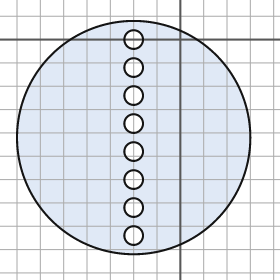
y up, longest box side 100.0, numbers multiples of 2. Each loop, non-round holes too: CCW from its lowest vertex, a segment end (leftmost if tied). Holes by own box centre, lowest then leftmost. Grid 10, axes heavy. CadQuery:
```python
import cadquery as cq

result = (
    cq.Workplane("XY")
    .moveTo(-20.0, -42.0)
    .circle(50.0)
    .moveTo(-20.0, -84.0)
    .circle(4.0)
    .moveTo(-20.0, -72.0)
    .circle(4.0)
    .moveTo(-20.0, -60.0)
    .circle(4.0)
    .moveTo(-20.0, -48.0)
    .circle(4.0)
    .moveTo(-20.0, -36.0)
    .circle(4.0)
    .moveTo(-20.0, -24.0)
    .circle(4.0)
    .moveTo(-20.0, -12.0)
    .circle(4.0)
    .moveTo(-20.0, 0.0)
    .circle(4.0)
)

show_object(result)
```